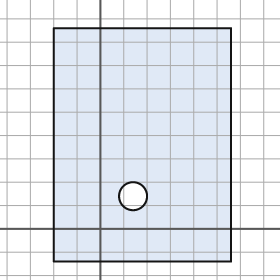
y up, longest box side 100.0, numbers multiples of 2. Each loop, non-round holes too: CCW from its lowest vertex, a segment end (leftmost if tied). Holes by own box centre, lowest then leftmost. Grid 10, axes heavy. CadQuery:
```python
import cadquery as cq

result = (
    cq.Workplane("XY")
    .moveTo(-20.0, -14.0)
    .lineTo(56.0, -14.0)
    .lineTo(56.0, 86.0)
    .lineTo(-20.0, 86.0)
    .close()
    .moveTo(14.0, 14.0)
    .circle(6.0)
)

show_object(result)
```